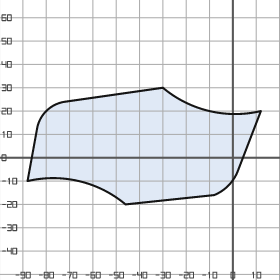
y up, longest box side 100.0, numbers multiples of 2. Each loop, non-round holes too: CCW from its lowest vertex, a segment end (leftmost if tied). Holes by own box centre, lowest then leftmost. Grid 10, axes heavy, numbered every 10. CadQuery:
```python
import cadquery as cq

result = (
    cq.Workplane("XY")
    .moveTo(-46.0, -20.0)
    .lineTo(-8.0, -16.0)
    .threePointArc((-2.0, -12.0), (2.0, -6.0))
    .lineTo(12.0, 20.0)
    .threePointArc((-10.0, 20.0), (-30.0, 30.0))
    .lineTo(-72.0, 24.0)
    .threePointArc((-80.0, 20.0), (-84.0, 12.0))
    .lineTo(-88.0, -10.0)
    .threePointArc((-66.0, -10.0), (-46.0, -20.0))
    .close()
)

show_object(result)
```